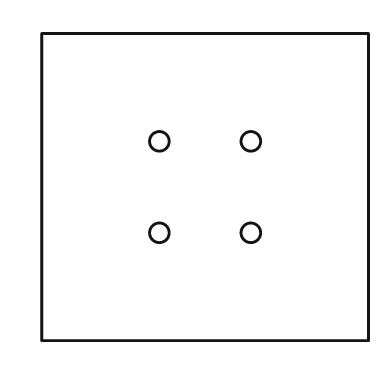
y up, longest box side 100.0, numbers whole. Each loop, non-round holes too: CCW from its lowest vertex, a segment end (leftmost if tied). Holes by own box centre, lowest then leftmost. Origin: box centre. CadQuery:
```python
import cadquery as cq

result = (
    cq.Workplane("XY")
    .moveTo(-50.0, -47.0)
    .lineTo(50.0, -47.0)
    .lineTo(50.0, 47.0)
    .lineTo(-50.0, 47.0)
    .close()
    .moveTo(-14.0, -14.0)
    .circle(3.0)
    .moveTo(14.0, -14.0)
    .circle(3.0)
    .moveTo(-14.0, 14.0)
    .circle(3.0)
    .moveTo(14.0, 14.0)
    .circle(3.0)
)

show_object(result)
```